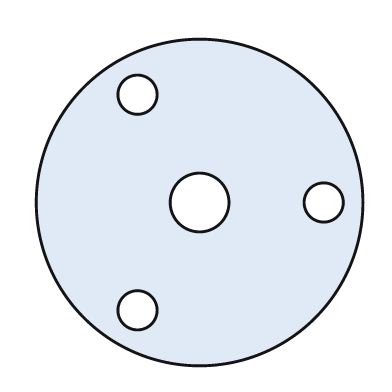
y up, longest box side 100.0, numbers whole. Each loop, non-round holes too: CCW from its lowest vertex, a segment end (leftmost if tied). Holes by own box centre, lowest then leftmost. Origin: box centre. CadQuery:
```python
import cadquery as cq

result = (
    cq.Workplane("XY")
    .moveTo(0.0, 0.0)
    .circle(50.0)
    .moveTo(-19.0, -33.0)
    .circle(6.0)
    .moveTo(0.0, 0.0)
    .circle(9.0)
    .moveTo(38.0, 0.0)
    .circle(6.0)
    .moveTo(-19.0, 33.0)
    .circle(6.0)
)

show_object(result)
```